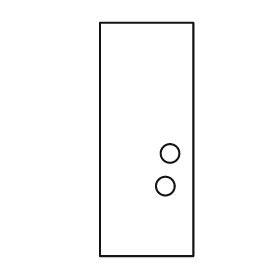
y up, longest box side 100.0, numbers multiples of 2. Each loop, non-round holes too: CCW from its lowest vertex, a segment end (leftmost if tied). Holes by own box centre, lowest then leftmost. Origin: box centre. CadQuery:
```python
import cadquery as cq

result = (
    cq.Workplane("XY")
    .moveTo(-20.0, -50.0)
    .lineTo(20.0, -50.0)
    .lineTo(20.0, 50.0)
    .lineTo(-20.0, 50.0)
    .close()
    .moveTo(8.0, -20.0)
    .circle(4.0)
    .moveTo(10.0, -6.0)
    .circle(4.0)
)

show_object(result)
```